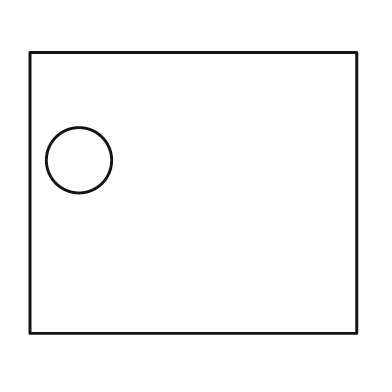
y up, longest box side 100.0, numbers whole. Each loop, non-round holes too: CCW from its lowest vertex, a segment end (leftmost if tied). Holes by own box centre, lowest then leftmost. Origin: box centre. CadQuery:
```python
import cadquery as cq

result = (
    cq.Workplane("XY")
    .moveTo(-50.0, -43.0)
    .lineTo(50.0, -43.0)
    .lineTo(50.0, 43.0)
    .lineTo(-50.0, 43.0)
    .close()
    .moveTo(-35.0, 10.0)
    .circle(10.0)
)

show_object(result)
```